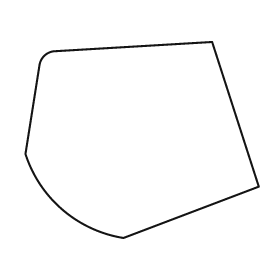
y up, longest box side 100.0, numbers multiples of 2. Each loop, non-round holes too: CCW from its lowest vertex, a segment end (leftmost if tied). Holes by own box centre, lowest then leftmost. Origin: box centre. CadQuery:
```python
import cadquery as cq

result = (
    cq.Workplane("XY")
    .moveTo(-8.0, -42.0)
    .lineTo(50.0, -20.0)
    .lineTo(30.0, 42.0)
    .lineTo(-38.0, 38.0)
    .threePointArc((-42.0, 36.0), (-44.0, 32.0))
    .lineTo(-50.0, -6.0)
    .threePointArc((-34.0, -30.0), (-8.0, -42.0))
    .close()
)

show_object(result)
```